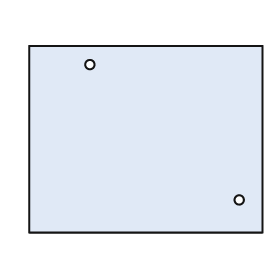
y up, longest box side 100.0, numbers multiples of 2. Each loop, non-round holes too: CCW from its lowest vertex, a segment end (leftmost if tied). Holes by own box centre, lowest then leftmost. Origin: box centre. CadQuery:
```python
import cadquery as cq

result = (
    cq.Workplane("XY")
    .moveTo(-50.0, -40.0)
    .lineTo(50.0, -40.0)
    .lineTo(50.0, 40.0)
    .lineTo(-50.0, 40.0)
    .close()
    .moveTo(40.0, -26.0)
    .circle(2.0)
    .moveTo(-24.0, 32.0)
    .circle(2.0)
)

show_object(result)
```